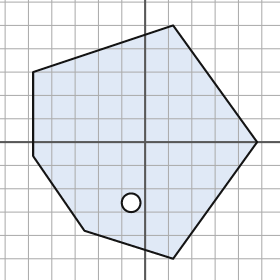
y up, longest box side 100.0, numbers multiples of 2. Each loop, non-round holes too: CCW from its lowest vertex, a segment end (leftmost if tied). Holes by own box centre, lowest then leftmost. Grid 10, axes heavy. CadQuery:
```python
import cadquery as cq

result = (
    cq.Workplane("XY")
    .moveTo(12.0, -50.0)
    .lineTo(48.0, 0.0)
    .lineTo(12.0, 50.0)
    .lineTo(-48.0, 30.0)
    .lineTo(-48.0, -6.0)
    .lineTo(-26.0, -38.0)
    .close()
    .moveTo(-6.0, -26.0)
    .circle(4.0)
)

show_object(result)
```